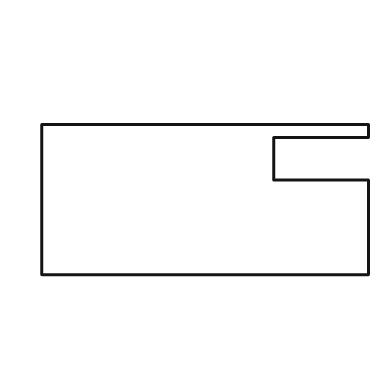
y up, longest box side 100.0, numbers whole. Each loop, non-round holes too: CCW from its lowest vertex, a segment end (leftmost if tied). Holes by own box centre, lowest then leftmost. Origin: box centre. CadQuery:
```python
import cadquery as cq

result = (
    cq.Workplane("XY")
    .moveTo(-50.0, -23.0)
    .lineTo(50.0, -23.0)
    .lineTo(50.0, 6.0)
    .lineTo(21.0, 6.0)
    .lineTo(21.0, 19.0)
    .lineTo(50.0, 19.0)
    .lineTo(50.0, 23.0)
    .lineTo(-50.0, 23.0)
    .close()
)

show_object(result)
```